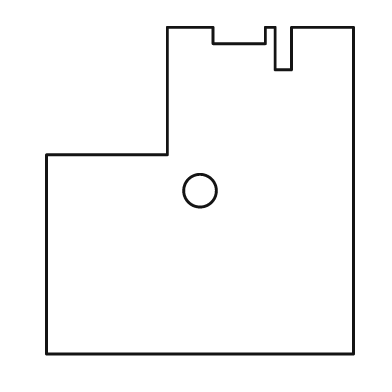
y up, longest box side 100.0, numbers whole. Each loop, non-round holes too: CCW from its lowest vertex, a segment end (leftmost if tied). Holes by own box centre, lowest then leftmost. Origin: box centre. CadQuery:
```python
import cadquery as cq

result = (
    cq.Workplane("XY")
    .moveTo(-47.0, -50.0)
    .lineTo(47.0, -50.0)
    .lineTo(47.0, 50.0)
    .lineTo(28.0, 50.0)
    .lineTo(28.0, 37.0)
    .lineTo(23.0, 37.0)
    .lineTo(23.0, 50.0)
    .lineTo(20.0, 50.0)
    .lineTo(20.0, 45.0)
    .lineTo(4.0, 45.0)
    .lineTo(4.0, 50.0)
    .lineTo(-10.0, 50.0)
    .lineTo(-10.0, 11.0)
    .lineTo(-47.0, 11.0)
    .close()
    .moveTo(0.0, 0.0)
    .circle(5.0)
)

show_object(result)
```